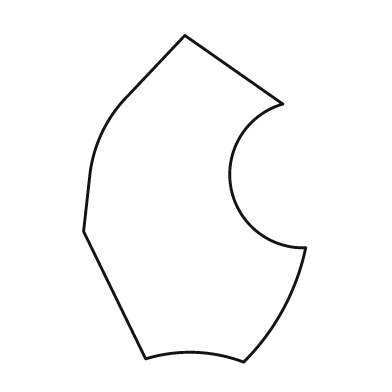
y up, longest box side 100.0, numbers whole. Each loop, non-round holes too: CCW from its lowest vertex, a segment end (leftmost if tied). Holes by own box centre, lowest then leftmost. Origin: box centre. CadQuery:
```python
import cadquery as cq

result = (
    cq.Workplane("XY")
    .moveTo(15.0, -50.0)
    .threePointArc((27.0, -34.0), (34.0, -15.0))
    .threePointArc((11.0, 4.0), (27.0, 29.0))
    .lineTo(-3.0, 50.0)
    .lineTo(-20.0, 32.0)
    .threePointArc((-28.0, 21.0), (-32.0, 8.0))
    .lineTo(-34.0, -10.0)
    .lineTo(-15.0, -49.0)
    .threePointArc((0.0, -47.0), (15.0, -50.0))
    .close()
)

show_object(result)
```